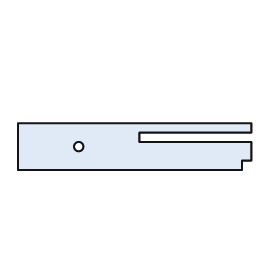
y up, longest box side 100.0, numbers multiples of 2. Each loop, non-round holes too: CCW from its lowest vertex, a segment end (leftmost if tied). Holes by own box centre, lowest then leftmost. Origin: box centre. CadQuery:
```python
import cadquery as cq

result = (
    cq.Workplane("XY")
    .moveTo(-50.0, -10.0)
    .lineTo(46.0, -10.0)
    .lineTo(46.0, -6.0)
    .lineTo(50.0, -6.0)
    .lineTo(50.0, 2.0)
    .lineTo(2.0, 2.0)
    .lineTo(2.0, 6.0)
    .lineTo(50.0, 6.0)
    .lineTo(50.0, 10.0)
    .lineTo(-50.0, 10.0)
    .close()
    .moveTo(-24.0, 0.0)
    .circle(2.0)
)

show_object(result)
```